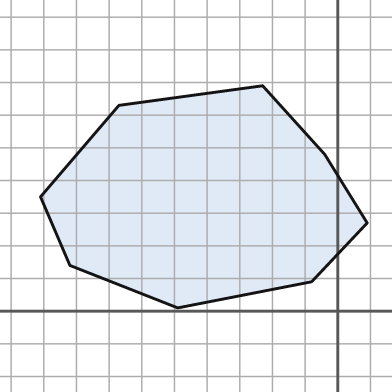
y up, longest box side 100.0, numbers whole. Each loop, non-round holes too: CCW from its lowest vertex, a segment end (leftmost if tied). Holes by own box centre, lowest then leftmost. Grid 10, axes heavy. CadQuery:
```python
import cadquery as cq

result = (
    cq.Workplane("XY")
    .moveTo(-49.0, 1.0)
    .lineTo(-8.0, 9.0)
    .lineTo(9.0, 27.0)
    .lineTo(-4.0, 48.0)
    .lineTo(-23.0, 69.0)
    .lineTo(-67.0, 63.0)
    .lineTo(-91.0, 35.0)
    .lineTo(-82.0, 14.0)
    .close()
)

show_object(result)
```